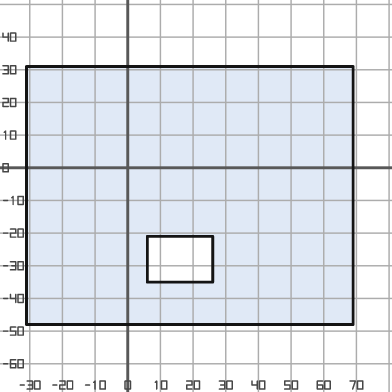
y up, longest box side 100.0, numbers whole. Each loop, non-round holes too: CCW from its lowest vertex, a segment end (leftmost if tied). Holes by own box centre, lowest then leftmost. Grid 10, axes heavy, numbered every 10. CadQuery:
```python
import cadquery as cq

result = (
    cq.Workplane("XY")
    .moveTo(-31.0, -48.0)
    .lineTo(69.0, -48.0)
    .lineTo(69.0, 31.0)
    .lineTo(-31.0, 31.0)
    .close()
    .moveTo(6.0, -35.0)
    .lineTo(26.0, -35.0)
    .lineTo(26.0, -21.0)
    .lineTo(6.0, -21.0)
    .close()
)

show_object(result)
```